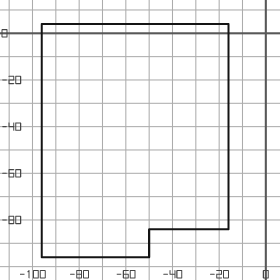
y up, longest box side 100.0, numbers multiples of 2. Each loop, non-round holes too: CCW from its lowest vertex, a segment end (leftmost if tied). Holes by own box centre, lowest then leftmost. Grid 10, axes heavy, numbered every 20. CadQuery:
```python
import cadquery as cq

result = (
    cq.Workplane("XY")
    .moveTo(-96.0, -96.0)
    .lineTo(-50.0, -96.0)
    .lineTo(-50.0, -84.0)
    .lineTo(-16.0, -84.0)
    .lineTo(-16.0, 4.0)
    .lineTo(-96.0, 4.0)
    .close()
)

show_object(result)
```